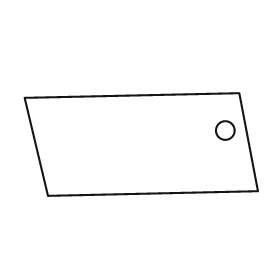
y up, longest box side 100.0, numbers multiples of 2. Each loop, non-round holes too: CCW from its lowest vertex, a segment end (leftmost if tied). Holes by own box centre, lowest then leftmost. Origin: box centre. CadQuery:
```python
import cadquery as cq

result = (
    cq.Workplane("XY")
    .moveTo(-40.0, -22.0)
    .lineTo(50.0, -20.0)
    .lineTo(42.0, 22.0)
    .lineTo(-50.0, 20.0)
    .close()
    .moveTo(36.0, 6.0)
    .circle(4.0)
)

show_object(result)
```